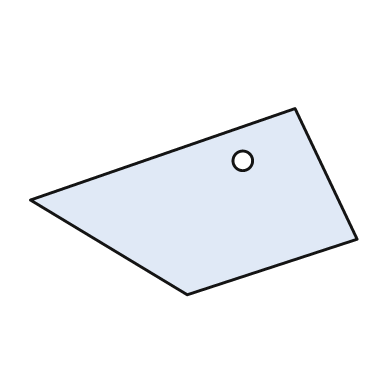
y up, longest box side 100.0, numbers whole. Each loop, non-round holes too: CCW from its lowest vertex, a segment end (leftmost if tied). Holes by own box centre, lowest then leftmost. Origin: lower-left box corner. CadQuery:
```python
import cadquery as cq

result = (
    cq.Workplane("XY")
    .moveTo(48.0, 0.0)
    .lineTo(100.0, 17.0)
    .lineTo(81.0, 57.0)
    .lineTo(0.0, 29.0)
    .close()
    .moveTo(65.0, 41.0)
    .circle(3.0)
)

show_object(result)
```